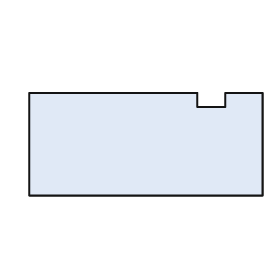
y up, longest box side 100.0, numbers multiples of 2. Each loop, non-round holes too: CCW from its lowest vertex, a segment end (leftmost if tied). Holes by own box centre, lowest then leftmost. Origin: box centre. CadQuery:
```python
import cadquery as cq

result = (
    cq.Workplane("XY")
    .moveTo(-50.0, -22.0)
    .lineTo(50.0, -22.0)
    .lineTo(50.0, 22.0)
    .lineTo(34.0, 22.0)
    .lineTo(34.0, 16.0)
    .lineTo(22.0, 16.0)
    .lineTo(22.0, 22.0)
    .lineTo(-50.0, 22.0)
    .close()
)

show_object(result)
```